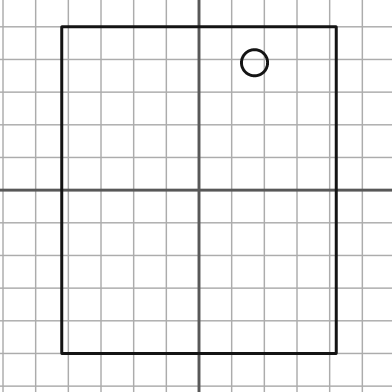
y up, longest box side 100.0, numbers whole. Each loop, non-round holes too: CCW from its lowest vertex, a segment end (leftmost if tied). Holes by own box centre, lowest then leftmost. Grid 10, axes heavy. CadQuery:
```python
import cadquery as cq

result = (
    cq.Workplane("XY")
    .moveTo(-42.0, -50.0)
    .lineTo(42.0, -50.0)
    .lineTo(42.0, 50.0)
    .lineTo(-42.0, 50.0)
    .close()
    .moveTo(17.0, 39.0)
    .circle(4.0)
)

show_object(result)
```